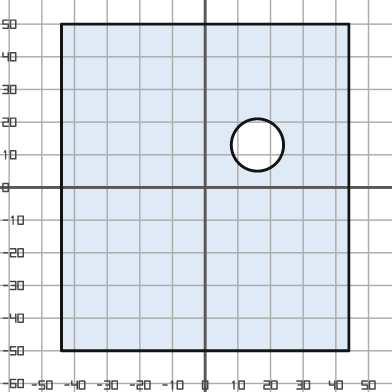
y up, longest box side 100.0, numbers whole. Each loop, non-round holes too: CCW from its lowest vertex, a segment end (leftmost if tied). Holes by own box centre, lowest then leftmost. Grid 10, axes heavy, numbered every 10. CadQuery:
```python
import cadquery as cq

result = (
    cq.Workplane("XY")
    .moveTo(-44.0, -50.0)
    .lineTo(44.0, -50.0)
    .lineTo(44.0, 50.0)
    .lineTo(-44.0, 50.0)
    .close()
    .moveTo(16.0, 13.0)
    .circle(8.0)
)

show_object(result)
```